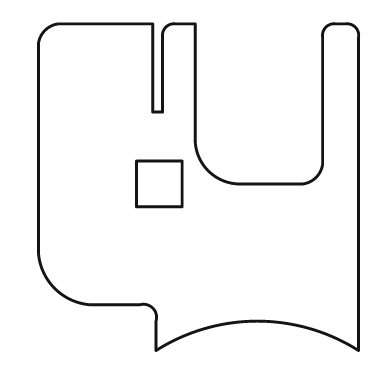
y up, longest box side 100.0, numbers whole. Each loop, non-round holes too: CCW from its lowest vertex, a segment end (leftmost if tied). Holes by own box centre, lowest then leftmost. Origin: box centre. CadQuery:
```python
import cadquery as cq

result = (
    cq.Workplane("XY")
    .moveTo(-13.0, -50.0)
    .threePointArc((18.0, -41.0), (49.0, -50.0))
    .lineTo(49.0, 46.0)
    .threePointArc((48.0, 49.0), (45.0, 50.0))
    .lineTo(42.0, 50.0)
    .threePointArc((39.0, 49.0), (38.0, 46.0))
    .lineTo(38.0, 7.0)
    .threePointArc((36.0, 3.0), (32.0, 1.0))
    .lineTo(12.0, 1.0)
    .threePointArc((3.0, 5.0), (-1.0, 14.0))
    .lineTo(-1.0, 50.0)
    .lineTo(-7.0, 50.0)
    .threePointArc((-10.0, 49.0), (-11.0, 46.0))
    .lineTo(-11.0, 23.0)
    .lineTo(-14.0, 23.0)
    .lineTo(-14.0, 50.0)
    .lineTo(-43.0, 50.0)
    .threePointArc((-47.0, 48.0), (-49.0, 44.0))
    .lineTo(-49.0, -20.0)
    .threePointArc((-44.0, -31.0), (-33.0, -36.0))
    .lineTo(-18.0, -36.0)
    .threePointArc((-14.0, -37.0), (-13.0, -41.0))
    .close()
    .moveTo(-19.0, -6.0)
    .lineTo(-5.0, -6.0)
    .lineTo(-5.0, 8.0)
    .lineTo(-19.0, 8.0)
    .close()
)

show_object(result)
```